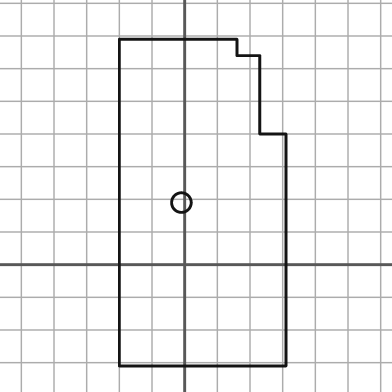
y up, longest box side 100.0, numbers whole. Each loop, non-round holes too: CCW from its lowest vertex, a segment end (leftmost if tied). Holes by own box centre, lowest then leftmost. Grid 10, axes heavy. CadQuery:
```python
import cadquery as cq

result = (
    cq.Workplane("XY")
    .moveTo(-20.0, -31.0)
    .lineTo(31.0, -31.0)
    .lineTo(31.0, 40.0)
    .lineTo(23.0, 40.0)
    .lineTo(23.0, 64.0)
    .lineTo(16.0, 64.0)
    .lineTo(16.0, 69.0)
    .lineTo(-20.0, 69.0)
    .close()
    .moveTo(-1.0, 19.0)
    .circle(3.0)
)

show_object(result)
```